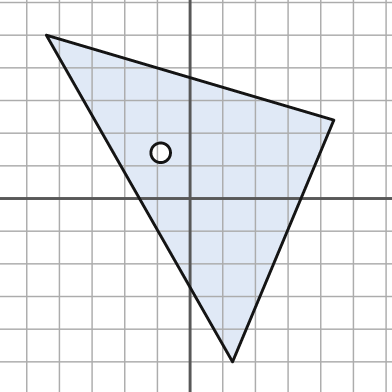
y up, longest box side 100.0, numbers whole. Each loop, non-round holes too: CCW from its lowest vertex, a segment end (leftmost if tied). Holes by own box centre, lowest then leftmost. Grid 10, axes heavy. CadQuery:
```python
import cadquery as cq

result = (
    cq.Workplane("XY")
    .moveTo(13.0, -50.0)
    .lineTo(44.0, 24.0)
    .lineTo(-44.0, 50.0)
    .close()
    .moveTo(-9.0, 14.0)
    .circle(3.0)
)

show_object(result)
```